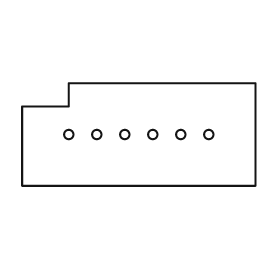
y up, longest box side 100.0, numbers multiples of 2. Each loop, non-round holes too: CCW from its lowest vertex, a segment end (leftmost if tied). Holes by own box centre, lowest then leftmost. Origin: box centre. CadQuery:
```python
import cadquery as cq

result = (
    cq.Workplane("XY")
    .moveTo(-50.0, -22.0)
    .lineTo(50.0, -22.0)
    .lineTo(50.0, 22.0)
    .lineTo(-30.0, 22.0)
    .lineTo(-30.0, 12.0)
    .lineTo(-50.0, 12.0)
    .close()
    .moveTo(-30.0, 0.0)
    .circle(2.0)
    .moveTo(-18.0, 0.0)
    .circle(2.0)
    .moveTo(-6.0, 0.0)
    .circle(2.0)
    .moveTo(6.0, 0.0)
    .circle(2.0)
    .moveTo(18.0, 0.0)
    .circle(2.0)
    .moveTo(30.0, 0.0)
    .circle(2.0)
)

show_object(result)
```